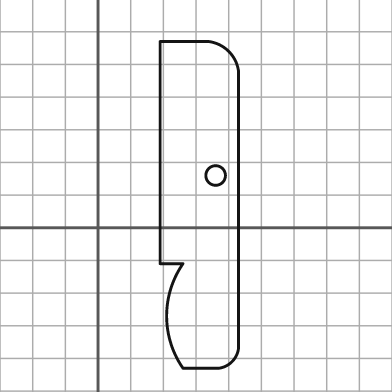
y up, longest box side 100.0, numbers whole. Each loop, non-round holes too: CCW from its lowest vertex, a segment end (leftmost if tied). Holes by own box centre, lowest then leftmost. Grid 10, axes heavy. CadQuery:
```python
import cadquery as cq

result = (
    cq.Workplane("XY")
    .moveTo(26.0, -43.0)
    .lineTo(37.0, -43.0)
    .threePointArc((41.0, -41.0), (43.0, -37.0))
    .lineTo(43.0, 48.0)
    .threePointArc((40.0, 54.0), (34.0, 57.0))
    .lineTo(19.0, 57.0)
    .lineTo(19.0, -11.0)
    .lineTo(26.0, -11.0)
    .threePointArc((21.0, -27.0), (26.0, -43.0))
    .close()
    .moveTo(36.0, 16.0)
    .circle(3.0)
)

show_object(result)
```